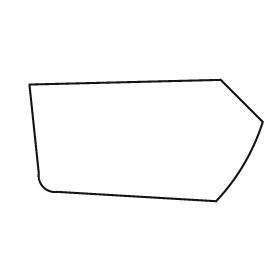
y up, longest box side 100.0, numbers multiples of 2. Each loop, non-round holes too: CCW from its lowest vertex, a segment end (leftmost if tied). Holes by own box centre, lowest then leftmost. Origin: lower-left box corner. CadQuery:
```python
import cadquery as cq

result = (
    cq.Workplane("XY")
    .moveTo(80.0, 0.0)
    .threePointArc((92.0, 16.0), (100.0, 34.0))
    .lineTo(82.0, 52.0)
    .lineTo(0.0, 50.0)
    .lineTo(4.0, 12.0)
    .threePointArc((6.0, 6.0), (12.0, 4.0))
    .close()
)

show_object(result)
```